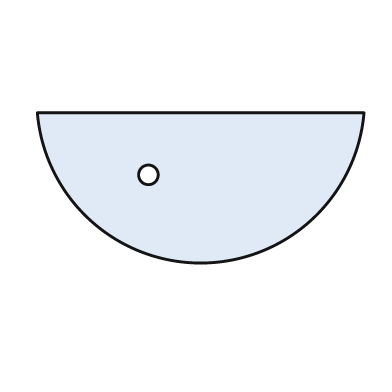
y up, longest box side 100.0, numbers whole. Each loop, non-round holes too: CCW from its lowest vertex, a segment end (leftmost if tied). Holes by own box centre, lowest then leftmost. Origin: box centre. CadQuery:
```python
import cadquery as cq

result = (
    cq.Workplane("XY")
    .moveTo(-50.0, 23.0)
    .threePointArc((0.0, -23.0), (50.0, 23.0))
    .close()
    .moveTo(-16.0, 4.0)
    .circle(3.0)
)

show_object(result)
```